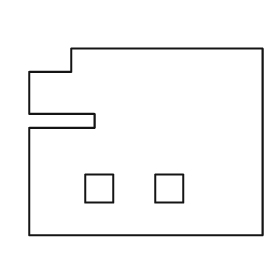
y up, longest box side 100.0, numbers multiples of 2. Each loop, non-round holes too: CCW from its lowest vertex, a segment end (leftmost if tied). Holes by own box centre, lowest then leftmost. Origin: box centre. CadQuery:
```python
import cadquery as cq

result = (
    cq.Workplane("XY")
    .moveTo(-50.0, -40.0)
    .lineTo(50.0, -40.0)
    .lineTo(50.0, 40.0)
    .lineTo(-32.0, 40.0)
    .lineTo(-32.0, 30.0)
    .lineTo(-50.0, 30.0)
    .lineTo(-50.0, 12.0)
    .lineTo(-22.0, 12.0)
    .lineTo(-22.0, 6.0)
    .lineTo(-50.0, 6.0)
    .close()
    .moveTo(-26.0, -26.0)
    .lineTo(-14.0, -26.0)
    .lineTo(-14.0, -14.0)
    .lineTo(-26.0, -14.0)
    .close()
    .moveTo(4.0, -26.0)
    .lineTo(16.0, -26.0)
    .lineTo(16.0, -14.0)
    .lineTo(4.0, -14.0)
    .close()
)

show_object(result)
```